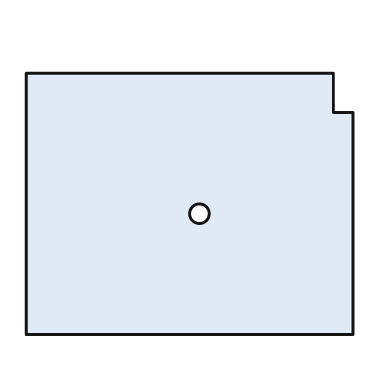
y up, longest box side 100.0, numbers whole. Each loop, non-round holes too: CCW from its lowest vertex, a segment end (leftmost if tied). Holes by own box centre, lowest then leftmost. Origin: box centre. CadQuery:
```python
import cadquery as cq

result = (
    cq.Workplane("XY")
    .moveTo(-50.0, -40.0)
    .lineTo(50.0, -40.0)
    .lineTo(50.0, 28.0)
    .lineTo(44.0, 28.0)
    .lineTo(44.0, 40.0)
    .lineTo(-50.0, 40.0)
    .close()
    .moveTo(3.0, -3.0)
    .circle(3.0)
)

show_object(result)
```